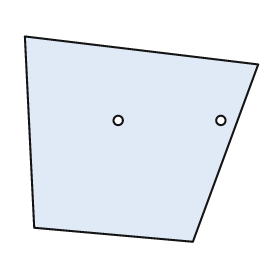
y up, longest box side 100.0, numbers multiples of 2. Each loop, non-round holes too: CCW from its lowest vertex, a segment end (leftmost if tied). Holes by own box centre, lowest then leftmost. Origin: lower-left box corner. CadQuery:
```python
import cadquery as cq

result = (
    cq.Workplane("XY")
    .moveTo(72.0, 0.0)
    .lineTo(100.0, 76.0)
    .lineTo(0.0, 88.0)
    .lineTo(4.0, 6.0)
    .close()
    .moveTo(40.0, 52.0)
    .circle(2.0)
    .moveTo(84.0, 52.0)
    .circle(2.0)
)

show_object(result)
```